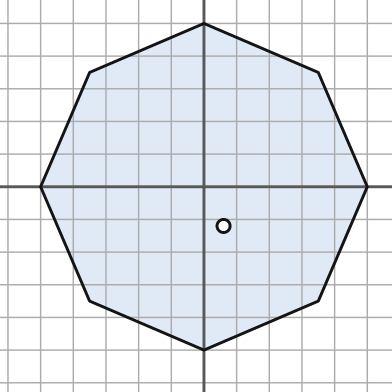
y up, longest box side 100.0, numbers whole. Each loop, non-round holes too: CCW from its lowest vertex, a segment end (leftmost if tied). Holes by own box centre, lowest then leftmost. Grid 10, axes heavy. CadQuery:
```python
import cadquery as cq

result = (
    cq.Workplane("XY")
    .moveTo(0.0, -50.0)
    .lineTo(35.0, -35.0)
    .lineTo(50.0, 0.0)
    .lineTo(35.0, 35.0)
    .lineTo(0.0, 50.0)
    .lineTo(-35.0, 35.0)
    .lineTo(-50.0, 0.0)
    .lineTo(-35.0, -35.0)
    .close()
    .moveTo(6.0, -12.0)
    .circle(2.0)
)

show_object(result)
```